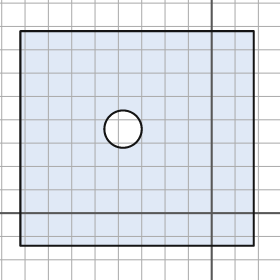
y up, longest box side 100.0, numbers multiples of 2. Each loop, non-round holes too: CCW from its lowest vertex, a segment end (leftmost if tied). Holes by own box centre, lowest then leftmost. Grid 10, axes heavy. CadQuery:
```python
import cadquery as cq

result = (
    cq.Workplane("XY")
    .moveTo(-82.0, -14.0)
    .lineTo(18.0, -14.0)
    .lineTo(18.0, 78.0)
    .lineTo(-82.0, 78.0)
    .close()
    .moveTo(-38.0, 36.0)
    .circle(8.0)
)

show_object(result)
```